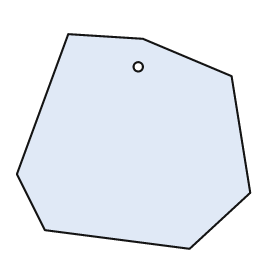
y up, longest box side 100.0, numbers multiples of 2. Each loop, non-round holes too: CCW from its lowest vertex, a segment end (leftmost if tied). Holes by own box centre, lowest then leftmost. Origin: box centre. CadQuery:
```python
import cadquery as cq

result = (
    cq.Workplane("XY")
    .moveTo(24.0, -46.0)
    .lineTo(50.0, -22.0)
    .lineTo(42.0, 28.0)
    .lineTo(4.0, 44.0)
    .lineTo(-28.0, 46.0)
    .lineTo(-50.0, -14.0)
    .lineTo(-38.0, -38.0)
    .close()
    .moveTo(2.0, 32.0)
    .circle(2.0)
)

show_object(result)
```